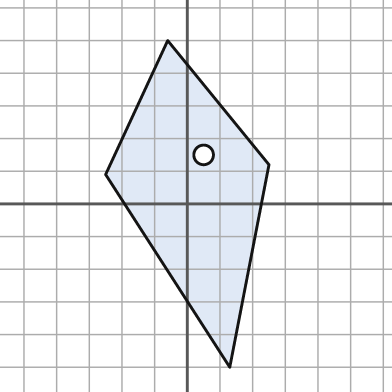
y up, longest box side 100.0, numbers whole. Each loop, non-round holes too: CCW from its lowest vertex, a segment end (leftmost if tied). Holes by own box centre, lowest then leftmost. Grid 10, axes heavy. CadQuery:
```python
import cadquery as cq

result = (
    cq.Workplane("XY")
    .moveTo(13.0, -50.0)
    .lineTo(25.0, 12.0)
    .lineTo(-6.0, 50.0)
    .lineTo(-25.0, 9.0)
    .close()
    .moveTo(5.0, 15.0)
    .circle(3.0)
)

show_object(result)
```